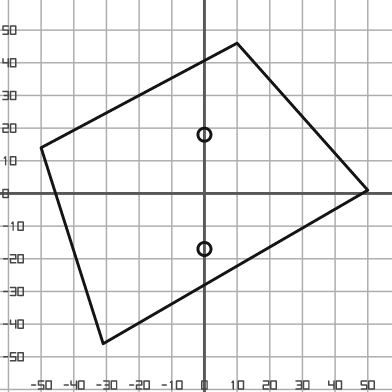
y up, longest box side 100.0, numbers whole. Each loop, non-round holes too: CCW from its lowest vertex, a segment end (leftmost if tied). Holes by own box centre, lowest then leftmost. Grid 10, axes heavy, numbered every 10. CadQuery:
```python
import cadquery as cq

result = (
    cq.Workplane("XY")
    .moveTo(-31.0, -46.0)
    .lineTo(50.0, 1.0)
    .lineTo(10.0, 46.0)
    .lineTo(-50.0, 14.0)
    .close()
    .moveTo(0.0, -17.0)
    .circle(2.0)
    .moveTo(0.0, 18.0)
    .circle(2.0)
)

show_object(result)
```